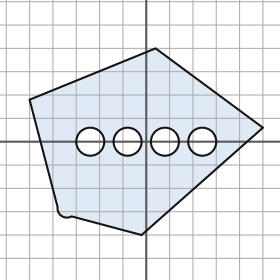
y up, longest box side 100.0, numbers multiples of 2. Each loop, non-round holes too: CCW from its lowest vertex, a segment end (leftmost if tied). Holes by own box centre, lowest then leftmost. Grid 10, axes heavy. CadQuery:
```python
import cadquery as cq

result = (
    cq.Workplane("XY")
    .moveTo(-2.0, -40.0)
    .lineTo(50.0, 6.0)
    .lineTo(4.0, 40.0)
    .lineTo(-50.0, 18.0)
    .lineTo(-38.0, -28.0)
    .threePointArc((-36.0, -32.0), (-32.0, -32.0))
    .close()
    .moveTo(-24.0, 0.0)
    .circle(6.0)
    .moveTo(-8.0, 0.0)
    .circle(6.0)
    .moveTo(8.0, 0.0)
    .circle(6.0)
    .moveTo(24.0, 0.0)
    .circle(6.0)
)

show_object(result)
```